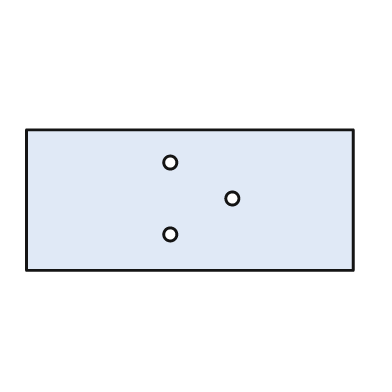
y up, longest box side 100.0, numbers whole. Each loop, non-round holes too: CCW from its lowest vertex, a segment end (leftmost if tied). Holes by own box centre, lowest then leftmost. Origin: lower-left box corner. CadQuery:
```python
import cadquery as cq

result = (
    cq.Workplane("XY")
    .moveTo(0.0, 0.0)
    .lineTo(100.0, 0.0)
    .lineTo(100.0, 43.0)
    .lineTo(0.0, 43.0)
    .close()
    .moveTo(44.0, 11.0)
    .circle(2.0)
    .moveTo(63.0, 22.0)
    .circle(2.0)
    .moveTo(44.0, 33.0)
    .circle(2.0)
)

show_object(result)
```